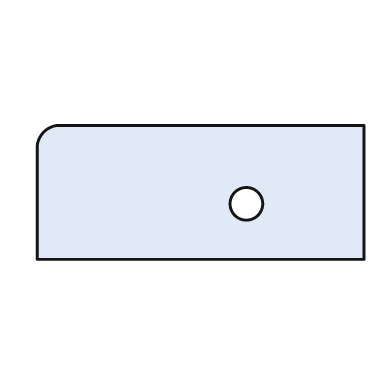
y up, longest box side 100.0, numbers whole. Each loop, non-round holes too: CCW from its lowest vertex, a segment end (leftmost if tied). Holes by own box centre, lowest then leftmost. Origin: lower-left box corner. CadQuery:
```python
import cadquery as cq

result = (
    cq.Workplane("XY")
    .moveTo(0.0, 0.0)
    .lineTo(100.0, 0.0)
    .lineTo(100.0, 41.0)
    .lineTo(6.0, 41.0)
    .threePointArc((2.0, 39.0), (0.0, 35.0))
    .close()
    .moveTo(64.0, 17.0)
    .circle(5.0)
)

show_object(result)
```